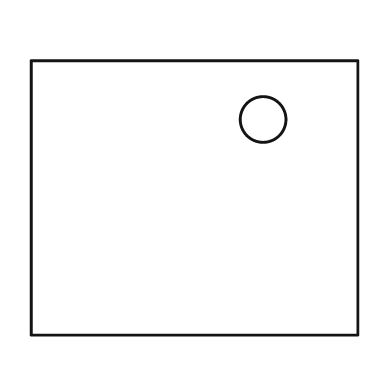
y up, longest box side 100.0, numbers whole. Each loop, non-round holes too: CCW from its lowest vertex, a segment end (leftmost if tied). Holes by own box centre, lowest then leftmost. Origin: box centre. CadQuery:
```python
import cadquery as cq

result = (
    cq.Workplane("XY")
    .moveTo(-50.0, -42.0)
    .lineTo(50.0, -42.0)
    .lineTo(50.0, 42.0)
    .lineTo(-50.0, 42.0)
    .close()
    .moveTo(21.0, 24.0)
    .circle(7.0)
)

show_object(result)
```